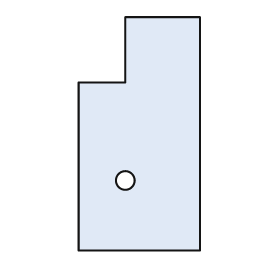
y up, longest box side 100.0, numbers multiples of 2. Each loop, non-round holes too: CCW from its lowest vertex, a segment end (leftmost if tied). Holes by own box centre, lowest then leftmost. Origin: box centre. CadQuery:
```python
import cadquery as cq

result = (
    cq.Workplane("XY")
    .moveTo(-26.0, -50.0)
    .lineTo(26.0, -50.0)
    .lineTo(26.0, 50.0)
    .lineTo(-6.0, 50.0)
    .lineTo(-6.0, 22.0)
    .lineTo(-26.0, 22.0)
    .close()
    .moveTo(-6.0, -20.0)
    .circle(4.0)
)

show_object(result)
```